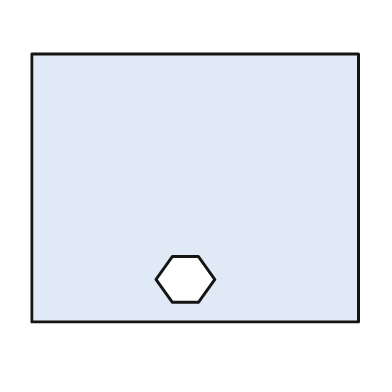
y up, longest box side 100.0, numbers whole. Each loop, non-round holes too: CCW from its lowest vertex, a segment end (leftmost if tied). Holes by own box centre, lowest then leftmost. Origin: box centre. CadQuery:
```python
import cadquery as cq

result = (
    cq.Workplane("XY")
    .moveTo(-50.0, -41.0)
    .lineTo(50.0, -41.0)
    .lineTo(50.0, 41.0)
    .lineTo(-50.0, 41.0)
    .close()
    .moveTo(-7.0, -35.0)
    .lineTo(1.0, -35.0)
    .lineTo(6.0, -28.0)
    .lineTo(1.0, -21.0)
    .lineTo(-7.0, -21.0)
    .lineTo(-12.0, -28.0)
    .close()
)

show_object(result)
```